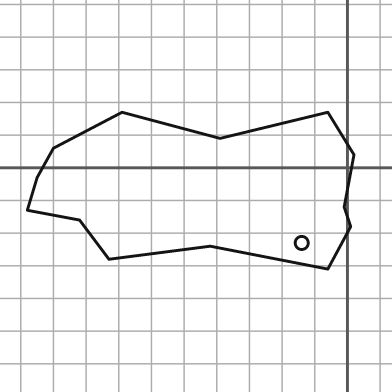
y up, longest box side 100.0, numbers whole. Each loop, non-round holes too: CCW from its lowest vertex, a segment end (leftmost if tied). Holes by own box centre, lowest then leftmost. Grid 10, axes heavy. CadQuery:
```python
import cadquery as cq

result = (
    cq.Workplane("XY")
    .moveTo(-6.0, -31.0)
    .lineTo(1.0, -18.0)
    .lineTo(-1.0, -12.0)
    .lineTo(2.0, 4.0)
    .lineTo(-6.0, 17.0)
    .lineTo(-39.0, 9.0)
    .lineTo(-69.0, 17.0)
    .lineTo(-90.0, 6.0)
    .lineTo(-95.0, -3.0)
    .lineTo(-98.0, -13.0)
    .lineTo(-82.0, -16.0)
    .lineTo(-73.0, -28.0)
    .lineTo(-42.0, -24.0)
    .close()
    .moveTo(-14.0, -23.0)
    .circle(2.0)
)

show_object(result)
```